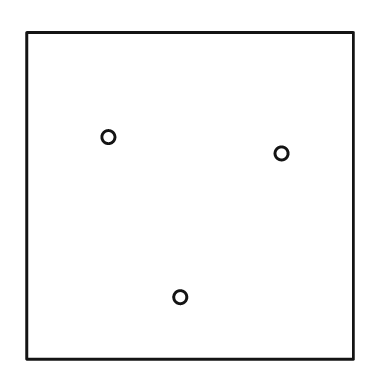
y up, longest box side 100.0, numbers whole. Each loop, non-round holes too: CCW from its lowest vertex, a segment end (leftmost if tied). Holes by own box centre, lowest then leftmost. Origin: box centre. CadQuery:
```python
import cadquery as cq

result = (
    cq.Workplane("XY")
    .moveTo(-50.0, -50.0)
    .lineTo(50.0, -50.0)
    .lineTo(50.0, 50.0)
    .lineTo(-50.0, 50.0)
    .close()
    .moveTo(-3.0, -31.0)
    .circle(2.0)
    .moveTo(28.0, 13.0)
    .circle(2.0)
    .moveTo(-25.0, 18.0)
    .circle(2.0)
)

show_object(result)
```